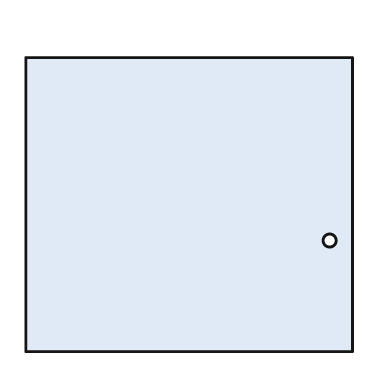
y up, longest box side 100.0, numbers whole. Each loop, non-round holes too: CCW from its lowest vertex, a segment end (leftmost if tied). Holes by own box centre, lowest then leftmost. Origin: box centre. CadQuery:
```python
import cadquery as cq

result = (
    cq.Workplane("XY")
    .moveTo(-50.0, -45.0)
    .lineTo(50.0, -45.0)
    .lineTo(50.0, 45.0)
    .lineTo(-50.0, 45.0)
    .close()
    .moveTo(43.0, -11.0)
    .circle(2.0)
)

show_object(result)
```